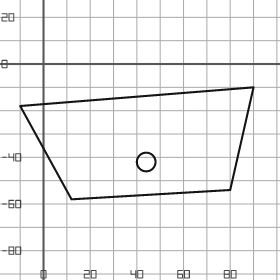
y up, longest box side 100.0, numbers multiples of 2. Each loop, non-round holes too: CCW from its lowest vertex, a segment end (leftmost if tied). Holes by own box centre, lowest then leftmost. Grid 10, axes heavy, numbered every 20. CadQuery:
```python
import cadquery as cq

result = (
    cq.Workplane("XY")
    .moveTo(12.0, -58.0)
    .lineTo(80.0, -54.0)
    .lineTo(90.0, -10.0)
    .lineTo(-10.0, -18.0)
    .close()
    .moveTo(44.0, -42.0)
    .circle(4.0)
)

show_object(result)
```